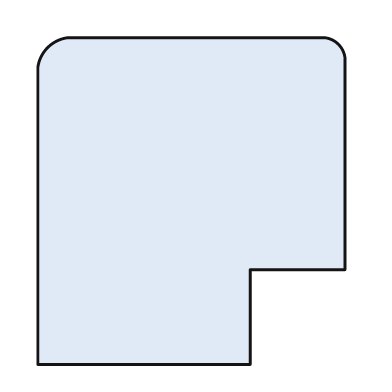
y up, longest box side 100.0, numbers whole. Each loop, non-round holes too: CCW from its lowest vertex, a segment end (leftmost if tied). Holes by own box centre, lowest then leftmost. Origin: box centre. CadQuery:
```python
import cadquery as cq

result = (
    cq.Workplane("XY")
    .moveTo(-47.0, -50.0)
    .lineTo(18.0, -50.0)
    .lineTo(18.0, -21.0)
    .lineTo(47.0, -21.0)
    .lineTo(47.0, 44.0)
    .threePointArc((45.0, 48.0), (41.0, 50.0))
    .lineTo(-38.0, 50.0)
    .threePointArc((-44.0, 47.0), (-47.0, 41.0))
    .close()
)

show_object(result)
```